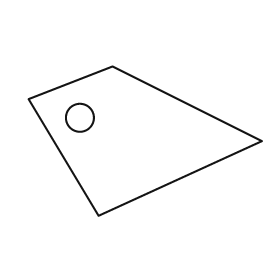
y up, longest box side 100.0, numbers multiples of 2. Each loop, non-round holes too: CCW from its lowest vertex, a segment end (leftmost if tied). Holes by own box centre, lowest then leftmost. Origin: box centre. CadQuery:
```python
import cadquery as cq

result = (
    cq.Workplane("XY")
    .moveTo(-20.0, -32.0)
    .lineTo(50.0, 0.0)
    .lineTo(-14.0, 32.0)
    .lineTo(-50.0, 18.0)
    .close()
    .moveTo(-28.0, 10.0)
    .circle(6.0)
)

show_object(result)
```